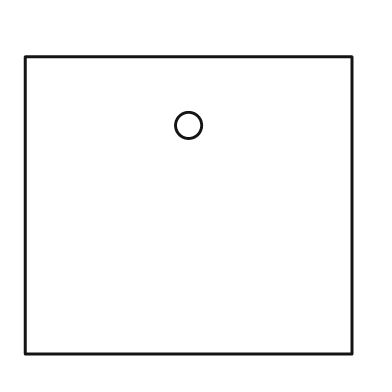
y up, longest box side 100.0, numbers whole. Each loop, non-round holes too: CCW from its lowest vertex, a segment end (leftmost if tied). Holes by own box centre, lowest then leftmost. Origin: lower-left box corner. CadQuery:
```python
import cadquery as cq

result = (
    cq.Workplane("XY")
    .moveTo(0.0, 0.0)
    .lineTo(100.0, 0.0)
    .lineTo(100.0, 91.0)
    .lineTo(0.0, 91.0)
    .close()
    .moveTo(50.0, 70.0)
    .circle(4.0)
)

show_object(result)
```